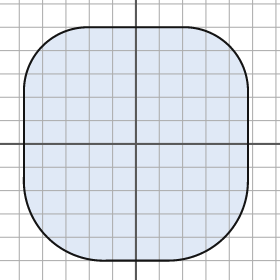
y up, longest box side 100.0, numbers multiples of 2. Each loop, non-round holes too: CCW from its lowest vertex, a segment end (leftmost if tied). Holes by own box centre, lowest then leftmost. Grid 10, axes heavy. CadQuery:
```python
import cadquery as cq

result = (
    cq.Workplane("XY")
    .moveTo(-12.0, -50.0)
    .lineTo(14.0, -50.0)
    .threePointArc((38.0, -40.0), (48.0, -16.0))
    .lineTo(48.0, 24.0)
    .threePointArc((40.0, 42.0), (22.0, 50.0))
    .lineTo(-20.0, 50.0)
    .threePointArc((-40.0, 42.0), (-48.0, 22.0))
    .lineTo(-48.0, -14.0)
    .threePointArc((-38.0, -40.0), (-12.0, -50.0))
    .close()
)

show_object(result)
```